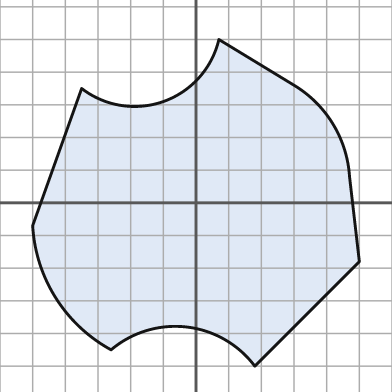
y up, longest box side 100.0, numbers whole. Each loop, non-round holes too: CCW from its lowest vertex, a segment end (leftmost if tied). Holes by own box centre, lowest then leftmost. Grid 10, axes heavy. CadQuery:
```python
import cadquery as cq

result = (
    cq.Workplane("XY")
    .moveTo(18.0, -50.0)
    .lineTo(50.0, -18.0)
    .lineTo(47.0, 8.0)
    .threePointArc((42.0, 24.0), (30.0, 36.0))
    .lineTo(7.0, 50.0)
    .threePointArc((-10.0, 31.0), (-35.0, 35.0))
    .lineTo(-50.0, -7.0)
    .threePointArc((-43.0, -29.0), (-26.0, -45.0))
    .threePointArc((-3.0, -38.0), (18.0, -50.0))
    .close()
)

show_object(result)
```